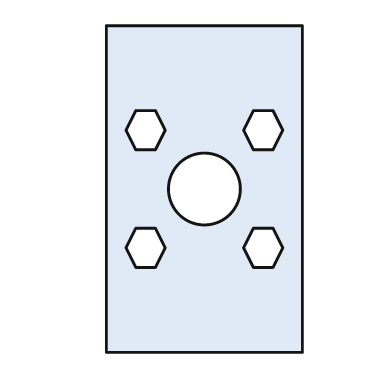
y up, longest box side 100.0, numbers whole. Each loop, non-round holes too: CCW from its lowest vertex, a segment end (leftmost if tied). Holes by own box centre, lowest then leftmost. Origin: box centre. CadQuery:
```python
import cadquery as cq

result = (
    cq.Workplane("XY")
    .moveTo(-30.0, -50.0)
    .lineTo(30.0, -50.0)
    .lineTo(30.0, 50.0)
    .lineTo(-30.0, 50.0)
    .close()
    .moveTo(-21.0, -24.0)
    .lineTo(-15.0, -24.0)
    .lineTo(-12.0, -18.0)
    .lineTo(-15.0, -12.0)
    .lineTo(-21.0, -12.0)
    .lineTo(-24.0, -18.0)
    .close()
    .moveTo(15.0, -24.0)
    .lineTo(21.0, -24.0)
    .lineTo(24.0, -18.0)
    .lineTo(21.0, -12.0)
    .lineTo(15.0, -12.0)
    .lineTo(12.0, -18.0)
    .close()
    .moveTo(0.0, 0.0)
    .circle(11.0)
    .moveTo(-21.0, 12.0)
    .lineTo(-15.0, 12.0)
    .lineTo(-12.0, 18.0)
    .lineTo(-15.0, 24.0)
    .lineTo(-21.0, 24.0)
    .lineTo(-24.0, 18.0)
    .close()
    .moveTo(15.0, 12.0)
    .lineTo(21.0, 12.0)
    .lineTo(24.0, 18.0)
    .lineTo(21.0, 24.0)
    .lineTo(15.0, 24.0)
    .lineTo(12.0, 18.0)
    .close()
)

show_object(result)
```